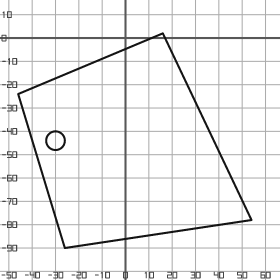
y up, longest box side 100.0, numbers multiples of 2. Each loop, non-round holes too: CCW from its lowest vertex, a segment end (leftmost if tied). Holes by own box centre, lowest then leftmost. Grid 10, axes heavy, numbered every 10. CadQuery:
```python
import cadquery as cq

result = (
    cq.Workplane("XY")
    .moveTo(-26.0, -90.0)
    .lineTo(54.0, -78.0)
    .lineTo(16.0, 2.0)
    .lineTo(-46.0, -24.0)
    .close()
    .moveTo(-30.0, -44.0)
    .circle(4.0)
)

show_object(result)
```